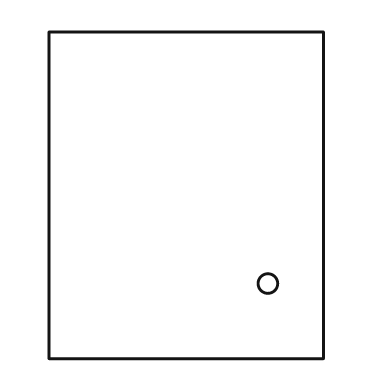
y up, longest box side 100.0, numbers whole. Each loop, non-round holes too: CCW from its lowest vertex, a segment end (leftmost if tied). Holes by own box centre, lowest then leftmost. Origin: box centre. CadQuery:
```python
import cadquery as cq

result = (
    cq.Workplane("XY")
    .moveTo(-42.0, -50.0)
    .lineTo(42.0, -50.0)
    .lineTo(42.0, 50.0)
    .lineTo(-42.0, 50.0)
    .close()
    .moveTo(25.0, -27.0)
    .circle(3.0)
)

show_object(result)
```